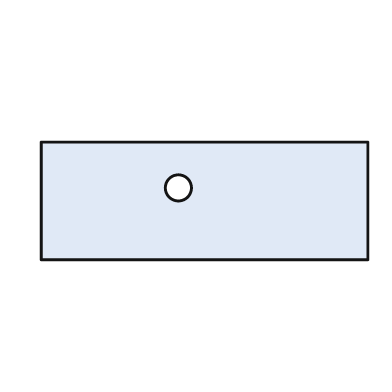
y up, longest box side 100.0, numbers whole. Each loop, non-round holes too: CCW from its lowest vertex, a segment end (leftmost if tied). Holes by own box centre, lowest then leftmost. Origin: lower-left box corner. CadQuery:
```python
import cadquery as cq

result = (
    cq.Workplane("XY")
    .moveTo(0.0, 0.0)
    .lineTo(100.0, 0.0)
    .lineTo(100.0, 36.0)
    .lineTo(0.0, 36.0)
    .close()
    .moveTo(42.0, 22.0)
    .circle(4.0)
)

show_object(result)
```